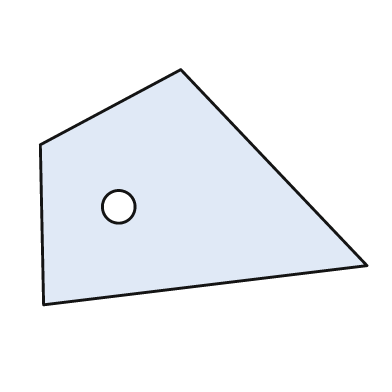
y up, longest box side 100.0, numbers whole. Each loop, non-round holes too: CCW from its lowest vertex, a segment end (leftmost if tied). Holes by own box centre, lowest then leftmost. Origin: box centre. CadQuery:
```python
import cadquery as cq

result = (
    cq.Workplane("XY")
    .moveTo(-49.0, -36.0)
    .lineTo(50.0, -24.0)
    .lineTo(-7.0, 36.0)
    .lineTo(-50.0, 13.0)
    .close()
    .moveTo(-26.0, -6.0)
    .circle(5.0)
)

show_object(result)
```